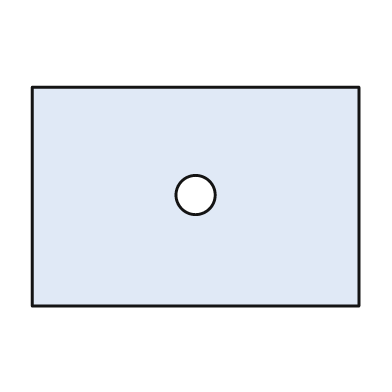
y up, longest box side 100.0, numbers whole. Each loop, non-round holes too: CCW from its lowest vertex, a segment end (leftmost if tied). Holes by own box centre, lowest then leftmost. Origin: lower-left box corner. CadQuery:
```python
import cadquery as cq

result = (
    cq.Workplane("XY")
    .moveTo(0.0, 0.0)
    .lineTo(100.0, 0.0)
    .lineTo(100.0, 67.0)
    .lineTo(0.0, 67.0)
    .close()
    .moveTo(50.0, 34.0)
    .circle(6.0)
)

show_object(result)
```